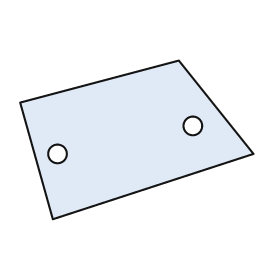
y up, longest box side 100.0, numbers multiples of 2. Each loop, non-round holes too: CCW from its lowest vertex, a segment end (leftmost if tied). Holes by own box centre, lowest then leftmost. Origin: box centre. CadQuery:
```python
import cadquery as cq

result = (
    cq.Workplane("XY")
    .moveTo(-36.0, -34.0)
    .lineTo(50.0, -6.0)
    .lineTo(18.0, 34.0)
    .lineTo(-50.0, 16.0)
    .close()
    .moveTo(-34.0, -6.0)
    .circle(4.0)
    .moveTo(24.0, 6.0)
    .circle(4.0)
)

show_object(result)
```